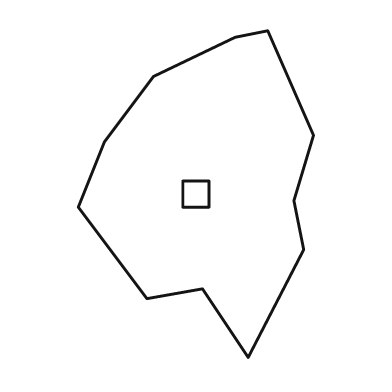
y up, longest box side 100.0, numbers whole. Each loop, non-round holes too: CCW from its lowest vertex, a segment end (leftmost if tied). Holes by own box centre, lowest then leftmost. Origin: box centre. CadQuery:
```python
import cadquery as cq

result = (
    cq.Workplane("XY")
    .moveTo(16.0, -50.0)
    .lineTo(33.0, -17.0)
    .lineTo(30.0, -2.0)
    .lineTo(36.0, 18.0)
    .lineTo(22.0, 50.0)
    .lineTo(12.0, 48.0)
    .lineTo(-13.0, 36.0)
    .lineTo(-28.0, 16.0)
    .lineTo(-36.0, -4.0)
    .lineTo(-15.0, -32.0)
    .lineTo(2.0, -29.0)
    .close()
    .moveTo(-4.0, -4.0)
    .lineTo(4.0, -4.0)
    .lineTo(4.0, 4.0)
    .lineTo(-4.0, 4.0)
    .close()
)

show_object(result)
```